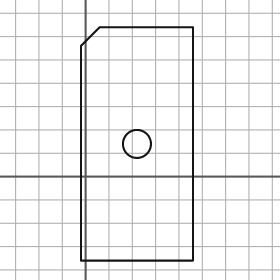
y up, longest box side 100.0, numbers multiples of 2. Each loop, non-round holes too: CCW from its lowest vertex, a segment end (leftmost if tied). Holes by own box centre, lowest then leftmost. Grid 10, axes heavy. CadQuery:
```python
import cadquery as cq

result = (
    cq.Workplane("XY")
    .moveTo(-2.0, -36.0)
    .lineTo(46.0, -36.0)
    .lineTo(46.0, 64.0)
    .lineTo(6.0, 64.0)
    .lineTo(-2.0, 56.0)
    .close()
    .moveTo(22.0, 14.0)
    .circle(6.0)
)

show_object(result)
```